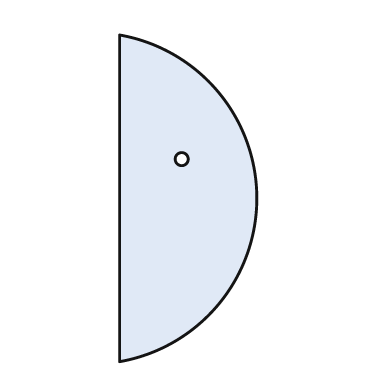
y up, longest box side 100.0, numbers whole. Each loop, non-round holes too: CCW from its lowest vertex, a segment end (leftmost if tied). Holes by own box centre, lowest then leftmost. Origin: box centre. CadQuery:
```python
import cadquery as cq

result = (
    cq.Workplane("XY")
    .moveTo(-21.0, -50.0)
    .threePointArc((21.0, 0.0), (-21.0, 50.0))
    .close()
    .moveTo(-2.0, 12.0)
    .circle(2.0)
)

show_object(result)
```